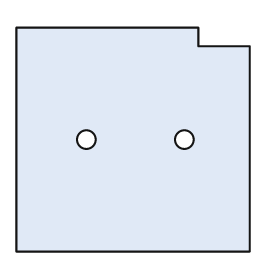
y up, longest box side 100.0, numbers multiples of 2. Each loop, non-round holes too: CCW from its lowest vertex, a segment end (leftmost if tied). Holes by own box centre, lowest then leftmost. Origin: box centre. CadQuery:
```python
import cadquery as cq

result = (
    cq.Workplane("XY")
    .moveTo(-50.0, -48.0)
    .lineTo(50.0, -48.0)
    .lineTo(50.0, 40.0)
    .lineTo(28.0, 40.0)
    .lineTo(28.0, 48.0)
    .lineTo(-50.0, 48.0)
    .close()
    .moveTo(-20.0, 0.0)
    .circle(4.0)
    .moveTo(22.0, 0.0)
    .circle(4.0)
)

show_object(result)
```